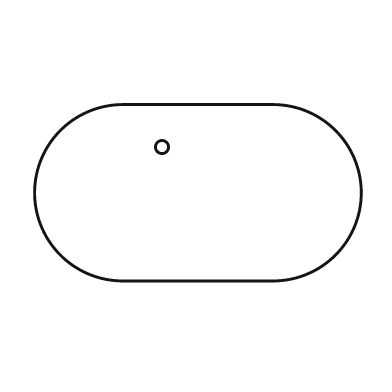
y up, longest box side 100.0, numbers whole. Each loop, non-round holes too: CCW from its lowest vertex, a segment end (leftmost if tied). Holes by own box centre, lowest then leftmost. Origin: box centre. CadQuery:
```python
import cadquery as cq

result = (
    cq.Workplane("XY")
    .moveTo(-23.0, -27.0)
    .lineTo(23.0, -27.0)
    .threePointArc((50.0, 0.0), (23.0, 27.0))
    .lineTo(-23.0, 27.0)
    .threePointArc((-50.0, 0.0), (-23.0, -27.0))
    .close()
    .moveTo(-11.0, 14.0)
    .circle(2.0)
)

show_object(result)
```